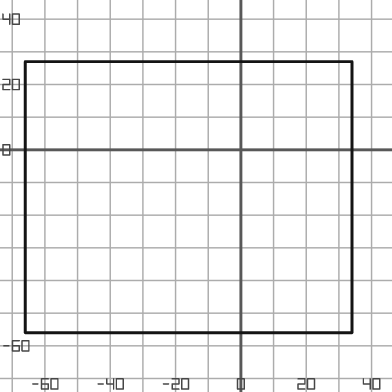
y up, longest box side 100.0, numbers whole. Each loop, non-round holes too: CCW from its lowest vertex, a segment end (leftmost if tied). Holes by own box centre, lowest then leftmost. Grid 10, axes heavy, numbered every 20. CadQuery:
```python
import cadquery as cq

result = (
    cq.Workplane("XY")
    .moveTo(-66.0, -56.0)
    .lineTo(34.0, -56.0)
    .lineTo(34.0, 27.0)
    .lineTo(-66.0, 27.0)
    .close()
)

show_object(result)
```